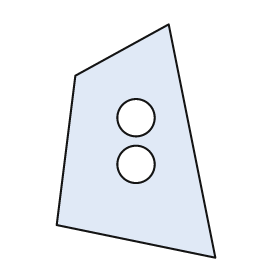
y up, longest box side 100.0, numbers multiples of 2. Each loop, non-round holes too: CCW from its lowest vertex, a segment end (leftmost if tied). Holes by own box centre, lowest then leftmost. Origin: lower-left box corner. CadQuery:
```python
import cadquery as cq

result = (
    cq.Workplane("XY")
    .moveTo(68.0, 0.0)
    .lineTo(48.0, 100.0)
    .lineTo(8.0, 78.0)
    .lineTo(0.0, 14.0)
    .close()
    .moveTo(34.0, 40.0)
    .circle(8.0)
    .moveTo(34.0, 60.0)
    .circle(8.0)
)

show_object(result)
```